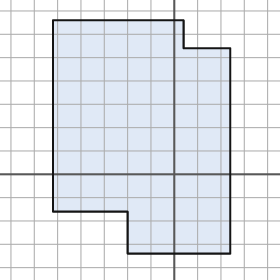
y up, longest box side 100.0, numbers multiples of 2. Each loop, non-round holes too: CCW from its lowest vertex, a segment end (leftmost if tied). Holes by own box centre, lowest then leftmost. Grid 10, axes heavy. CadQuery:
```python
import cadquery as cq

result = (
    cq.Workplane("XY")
    .moveTo(-20.0, -34.0)
    .lineTo(24.0, -34.0)
    .lineTo(24.0, 54.0)
    .lineTo(4.0, 54.0)
    .lineTo(4.0, 66.0)
    .lineTo(-52.0, 66.0)
    .lineTo(-52.0, -16.0)
    .lineTo(-20.0, -16.0)
    .close()
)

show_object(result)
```